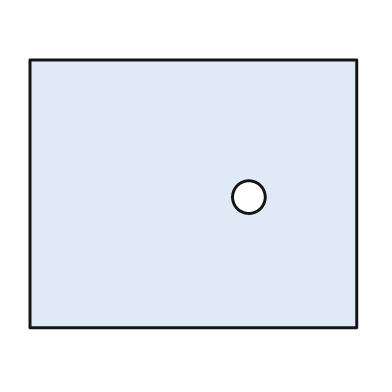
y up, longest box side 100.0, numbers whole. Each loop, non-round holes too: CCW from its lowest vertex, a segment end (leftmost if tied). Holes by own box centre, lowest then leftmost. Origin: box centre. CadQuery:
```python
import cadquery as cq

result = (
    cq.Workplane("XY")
    .moveTo(-50.0, -41.0)
    .lineTo(50.0, -41.0)
    .lineTo(50.0, 41.0)
    .lineTo(-50.0, 41.0)
    .close()
    .moveTo(17.0, -1.0)
    .circle(5.0)
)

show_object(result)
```